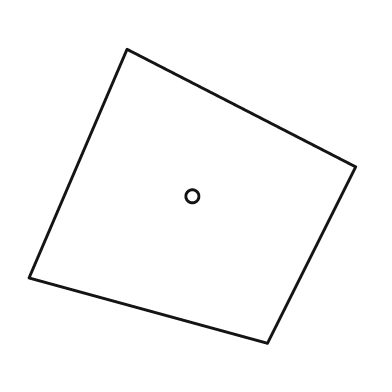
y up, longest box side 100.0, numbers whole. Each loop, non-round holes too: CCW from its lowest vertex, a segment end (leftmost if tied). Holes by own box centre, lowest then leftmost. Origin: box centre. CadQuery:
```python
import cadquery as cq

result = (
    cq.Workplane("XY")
    .moveTo(23.0, -45.0)
    .lineTo(50.0, 9.0)
    .lineTo(-20.0, 45.0)
    .lineTo(-50.0, -25.0)
    .close()
    .moveTo(0.0, 0.0)
    .circle(2.0)
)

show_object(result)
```